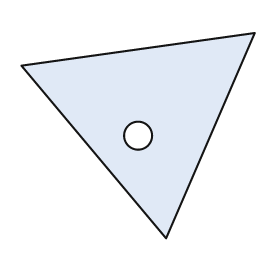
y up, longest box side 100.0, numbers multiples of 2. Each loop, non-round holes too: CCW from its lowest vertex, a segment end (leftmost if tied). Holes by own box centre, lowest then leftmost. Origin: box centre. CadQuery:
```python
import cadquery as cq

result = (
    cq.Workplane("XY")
    .moveTo(12.0, -44.0)
    .lineTo(50.0, 44.0)
    .lineTo(-50.0, 30.0)
    .close()
    .moveTo(0.0, 0.0)
    .circle(6.0)
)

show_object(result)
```